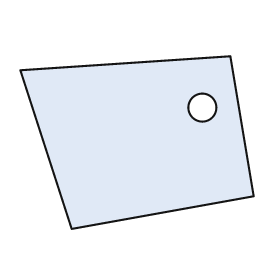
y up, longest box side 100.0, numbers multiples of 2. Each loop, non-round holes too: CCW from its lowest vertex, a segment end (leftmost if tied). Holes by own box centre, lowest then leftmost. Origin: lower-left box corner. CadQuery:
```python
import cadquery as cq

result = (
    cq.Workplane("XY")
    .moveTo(22.0, 0.0)
    .lineTo(100.0, 14.0)
    .lineTo(90.0, 74.0)
    .lineTo(0.0, 68.0)
    .close()
    .moveTo(78.0, 52.0)
    .circle(6.0)
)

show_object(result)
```